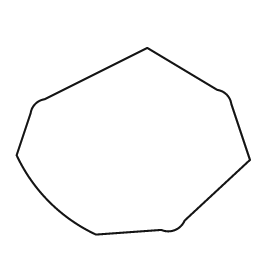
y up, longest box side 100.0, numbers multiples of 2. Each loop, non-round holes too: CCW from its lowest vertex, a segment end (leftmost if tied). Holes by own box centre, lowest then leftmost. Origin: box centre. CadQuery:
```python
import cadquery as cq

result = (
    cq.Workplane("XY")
    .moveTo(-16.0, -40.0)
    .lineTo(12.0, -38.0)
    .threePointArc((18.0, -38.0), (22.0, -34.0))
    .lineTo(50.0, -8.0)
    .lineTo(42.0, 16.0)
    .threePointArc((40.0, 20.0), (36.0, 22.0))
    .lineTo(6.0, 40.0)
    .lineTo(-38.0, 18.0)
    .threePointArc((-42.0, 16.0), (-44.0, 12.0))
    .lineTo(-50.0, -6.0)
    .threePointArc((-36.0, -26.0), (-16.0, -40.0))
    .close()
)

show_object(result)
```